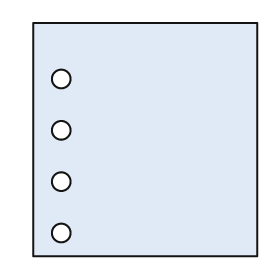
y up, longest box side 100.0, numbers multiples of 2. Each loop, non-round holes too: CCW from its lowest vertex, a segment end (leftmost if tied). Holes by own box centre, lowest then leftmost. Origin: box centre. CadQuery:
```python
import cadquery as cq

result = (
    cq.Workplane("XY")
    .moveTo(-48.0, -50.0)
    .lineTo(48.0, -50.0)
    .lineTo(48.0, 50.0)
    .lineTo(-48.0, 50.0)
    .close()
    .moveTo(-36.0, -40.0)
    .circle(4.0)
    .moveTo(-36.0, -18.0)
    .circle(4.0)
    .moveTo(-36.0, 4.0)
    .circle(4.0)
    .moveTo(-36.0, 26.0)
    .circle(4.0)
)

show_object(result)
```